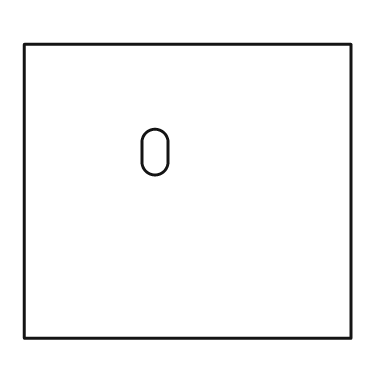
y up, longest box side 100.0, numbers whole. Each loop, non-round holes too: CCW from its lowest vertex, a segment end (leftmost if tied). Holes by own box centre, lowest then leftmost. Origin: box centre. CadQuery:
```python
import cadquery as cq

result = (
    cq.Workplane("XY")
    .moveTo(-50.0, -45.0)
    .lineTo(50.0, -45.0)
    .lineTo(50.0, 45.0)
    .lineTo(-50.0, 45.0)
    .close()
    .moveTo(-14.0, 9.0)
    .threePointArc((-10.0, 5.0), (-6.0, 9.0))
    .lineTo(-6.0, 15.0)
    .threePointArc((-10.0, 19.0), (-14.0, 15.0))
    .close()
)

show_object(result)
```